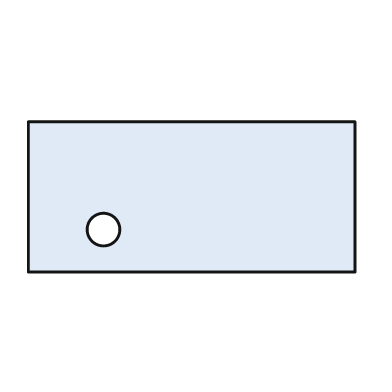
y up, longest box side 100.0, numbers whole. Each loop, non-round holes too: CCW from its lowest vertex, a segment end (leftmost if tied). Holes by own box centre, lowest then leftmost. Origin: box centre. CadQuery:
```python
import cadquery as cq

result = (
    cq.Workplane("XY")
    .moveTo(-50.0, -23.0)
    .lineTo(50.0, -23.0)
    .lineTo(50.0, 23.0)
    .lineTo(-50.0, 23.0)
    .close()
    .moveTo(-27.0, -10.0)
    .circle(5.0)
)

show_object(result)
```